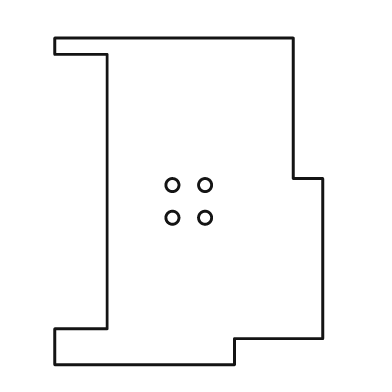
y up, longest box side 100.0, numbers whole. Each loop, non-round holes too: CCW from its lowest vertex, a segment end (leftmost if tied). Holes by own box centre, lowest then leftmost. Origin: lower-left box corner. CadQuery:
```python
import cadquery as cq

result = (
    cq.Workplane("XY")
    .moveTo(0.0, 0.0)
    .lineTo(55.0, 0.0)
    .lineTo(55.0, 8.0)
    .lineTo(82.0, 8.0)
    .lineTo(82.0, 57.0)
    .lineTo(73.0, 57.0)
    .lineTo(73.0, 100.0)
    .lineTo(0.0, 100.0)
    .lineTo(0.0, 95.0)
    .lineTo(16.0, 95.0)
    .lineTo(16.0, 11.0)
    .lineTo(0.0, 11.0)
    .close()
    .moveTo(36.0, 45.0)
    .circle(2.0)
    .moveTo(46.0, 45.0)
    .circle(2.0)
    .moveTo(36.0, 55.0)
    .circle(2.0)
    .moveTo(46.0, 55.0)
    .circle(2.0)
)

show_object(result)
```